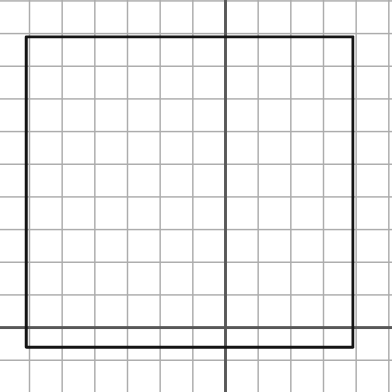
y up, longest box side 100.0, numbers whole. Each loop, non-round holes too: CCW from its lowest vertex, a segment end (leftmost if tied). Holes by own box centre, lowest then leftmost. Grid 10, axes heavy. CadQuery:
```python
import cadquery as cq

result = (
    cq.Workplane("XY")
    .moveTo(-61.0, -6.0)
    .lineTo(39.0, -6.0)
    .lineTo(39.0, 89.0)
    .lineTo(-61.0, 89.0)
    .close()
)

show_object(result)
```